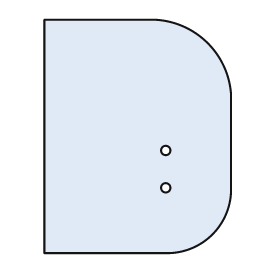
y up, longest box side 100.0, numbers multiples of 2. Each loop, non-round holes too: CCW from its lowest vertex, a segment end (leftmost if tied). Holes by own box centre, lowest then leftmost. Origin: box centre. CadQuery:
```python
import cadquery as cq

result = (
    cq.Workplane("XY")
    .moveTo(-40.0, -50.0)
    .lineTo(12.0, -50.0)
    .threePointArc((32.0, -42.0), (40.0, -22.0))
    .lineTo(40.0, 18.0)
    .threePointArc((30.0, 40.0), (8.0, 50.0))
    .lineTo(-40.0, 50.0)
    .close()
    .moveTo(12.0, -22.0)
    .circle(2.0)
    .moveTo(12.0, -6.0)
    .circle(2.0)
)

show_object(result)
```